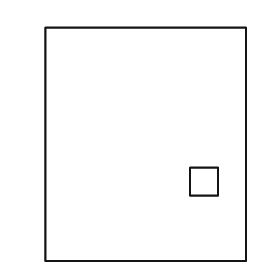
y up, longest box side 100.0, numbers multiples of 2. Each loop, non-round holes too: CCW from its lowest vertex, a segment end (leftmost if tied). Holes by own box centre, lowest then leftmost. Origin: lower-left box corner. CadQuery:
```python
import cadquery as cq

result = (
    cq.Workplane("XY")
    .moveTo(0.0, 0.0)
    .lineTo(86.0, 0.0)
    .lineTo(86.0, 100.0)
    .lineTo(0.0, 100.0)
    .close()
    .moveTo(62.0, 28.0)
    .lineTo(74.0, 28.0)
    .lineTo(74.0, 40.0)
    .lineTo(62.0, 40.0)
    .close()
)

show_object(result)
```